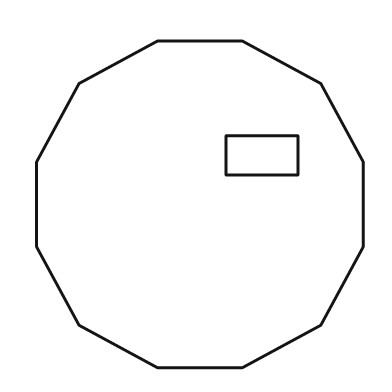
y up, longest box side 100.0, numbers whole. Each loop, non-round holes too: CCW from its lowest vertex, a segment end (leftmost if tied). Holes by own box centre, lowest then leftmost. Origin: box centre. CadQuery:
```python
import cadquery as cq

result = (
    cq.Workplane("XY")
    .moveTo(-13.0, -50.0)
    .lineTo(13.0, -50.0)
    .lineTo(37.0, -37.0)
    .lineTo(50.0, -13.0)
    .lineTo(50.0, 13.0)
    .lineTo(37.0, 37.0)
    .lineTo(13.0, 50.0)
    .lineTo(-13.0, 50.0)
    .lineTo(-37.0, 37.0)
    .lineTo(-50.0, 13.0)
    .lineTo(-50.0, -13.0)
    .lineTo(-37.0, -37.0)
    .close()
    .moveTo(8.0, 9.0)
    .lineTo(30.0, 9.0)
    .lineTo(30.0, 21.0)
    .lineTo(8.0, 21.0)
    .close()
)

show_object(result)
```